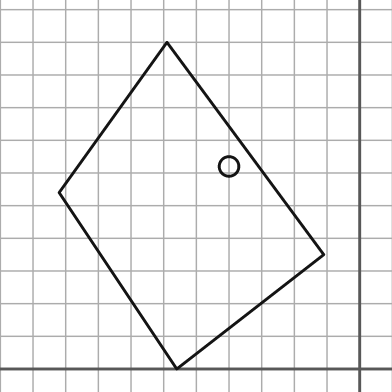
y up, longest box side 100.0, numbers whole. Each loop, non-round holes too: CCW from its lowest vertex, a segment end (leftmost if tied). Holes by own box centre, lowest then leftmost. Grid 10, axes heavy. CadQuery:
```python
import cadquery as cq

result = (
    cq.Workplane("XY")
    .moveTo(-56.0, 0.0)
    .lineTo(-11.0, 35.0)
    .lineTo(-59.0, 100.0)
    .lineTo(-92.0, 54.0)
    .close()
    .moveTo(-40.0, 62.0)
    .circle(3.0)
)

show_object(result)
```